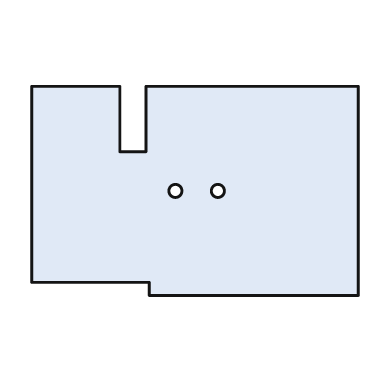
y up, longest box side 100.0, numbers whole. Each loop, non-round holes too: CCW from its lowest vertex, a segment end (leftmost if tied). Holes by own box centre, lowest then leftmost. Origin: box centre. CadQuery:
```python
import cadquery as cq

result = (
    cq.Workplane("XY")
    .moveTo(-14.0, -32.0)
    .lineTo(50.0, -32.0)
    .lineTo(50.0, 32.0)
    .lineTo(-15.0, 32.0)
    .lineTo(-15.0, 12.0)
    .lineTo(-23.0, 12.0)
    .lineTo(-23.0, 32.0)
    .lineTo(-50.0, 32.0)
    .lineTo(-50.0, -28.0)
    .lineTo(-14.0, -28.0)
    .close()
    .moveTo(-6.0, 0.0)
    .circle(2.0)
    .moveTo(7.0, 0.0)
    .circle(2.0)
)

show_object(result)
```